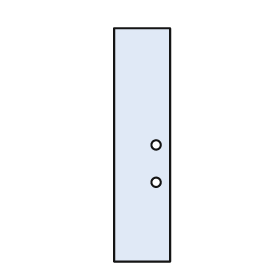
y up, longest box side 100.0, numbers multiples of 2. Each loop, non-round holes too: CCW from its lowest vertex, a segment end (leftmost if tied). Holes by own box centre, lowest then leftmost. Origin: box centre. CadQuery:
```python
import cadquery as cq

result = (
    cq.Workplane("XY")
    .moveTo(-12.0, -50.0)
    .lineTo(12.0, -50.0)
    .lineTo(12.0, 50.0)
    .lineTo(-12.0, 50.0)
    .close()
    .moveTo(6.0, -16.0)
    .circle(2.0)
    .moveTo(6.0, 0.0)
    .circle(2.0)
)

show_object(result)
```